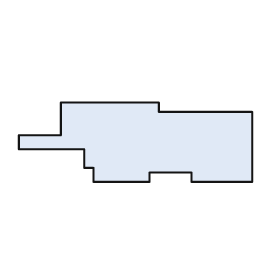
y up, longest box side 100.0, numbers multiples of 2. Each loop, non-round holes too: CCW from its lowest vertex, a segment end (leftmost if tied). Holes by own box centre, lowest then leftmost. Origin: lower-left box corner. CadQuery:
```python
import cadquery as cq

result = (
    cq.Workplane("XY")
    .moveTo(32.0, 0.0)
    .lineTo(56.0, 0.0)
    .lineTo(56.0, 4.0)
    .lineTo(74.0, 4.0)
    .lineTo(74.0, 0.0)
    .lineTo(100.0, 0.0)
    .lineTo(100.0, 30.0)
    .lineTo(60.0, 30.0)
    .lineTo(60.0, 34.0)
    .lineTo(18.0, 34.0)
    .lineTo(18.0, 20.0)
    .lineTo(0.0, 20.0)
    .lineTo(0.0, 14.0)
    .lineTo(28.0, 14.0)
    .lineTo(28.0, 6.0)
    .lineTo(32.0, 6.0)
    .close()
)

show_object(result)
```